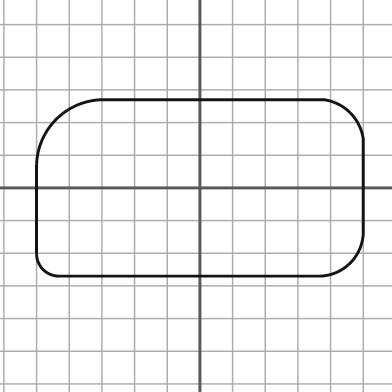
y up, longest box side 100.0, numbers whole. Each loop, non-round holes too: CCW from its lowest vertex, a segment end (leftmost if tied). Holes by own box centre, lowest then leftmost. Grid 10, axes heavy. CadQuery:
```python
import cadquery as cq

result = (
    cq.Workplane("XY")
    .moveTo(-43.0, -27.0)
    .lineTo(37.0, -27.0)
    .threePointArc((46.0, -23.0), (50.0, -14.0))
    .lineTo(50.0, 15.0)
    .threePointArc((46.0, 23.0), (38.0, 27.0))
    .lineTo(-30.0, 27.0)
    .threePointArc((-44.0, 21.0), (-50.0, 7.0))
    .lineTo(-50.0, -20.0)
    .threePointArc((-48.0, -25.0), (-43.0, -27.0))
    .close()
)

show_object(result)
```